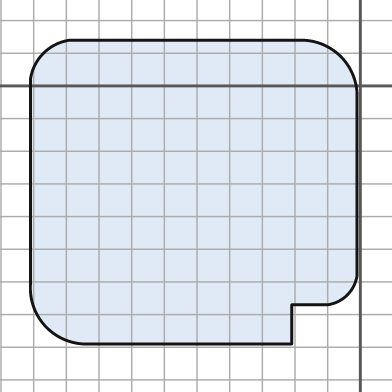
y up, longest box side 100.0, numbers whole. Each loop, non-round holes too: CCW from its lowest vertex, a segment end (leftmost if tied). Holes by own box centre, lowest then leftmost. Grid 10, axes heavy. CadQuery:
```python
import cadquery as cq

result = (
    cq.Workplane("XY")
    .moveTo(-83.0, -79.0)
    .lineTo(-21.0, -79.0)
    .lineTo(-21.0, -67.0)
    .lineTo(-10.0, -67.0)
    .threePointArc((-4.0, -64.0), (-1.0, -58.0))
    .lineTo(-1.0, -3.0)
    .threePointArc((-6.0, 9.0), (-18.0, 14.0))
    .lineTo(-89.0, 14.0)
    .threePointArc((-97.0, 10.0), (-101.0, 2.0))
    .lineTo(-101.0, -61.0)
    .threePointArc((-96.0, -74.0), (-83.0, -79.0))
    .close()
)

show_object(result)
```